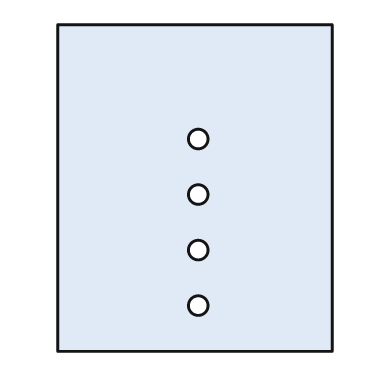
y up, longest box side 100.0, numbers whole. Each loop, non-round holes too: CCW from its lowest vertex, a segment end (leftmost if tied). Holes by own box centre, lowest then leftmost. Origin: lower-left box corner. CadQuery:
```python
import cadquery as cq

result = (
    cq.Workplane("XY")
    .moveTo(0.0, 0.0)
    .lineTo(84.0, 0.0)
    .lineTo(84.0, 100.0)
    .lineTo(0.0, 100.0)
    .close()
    .moveTo(43.0, 14.0)
    .circle(3.0)
    .moveTo(43.0, 31.0)
    .circle(3.0)
    .moveTo(43.0, 48.0)
    .circle(3.0)
    .moveTo(43.0, 65.0)
    .circle(3.0)
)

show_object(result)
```